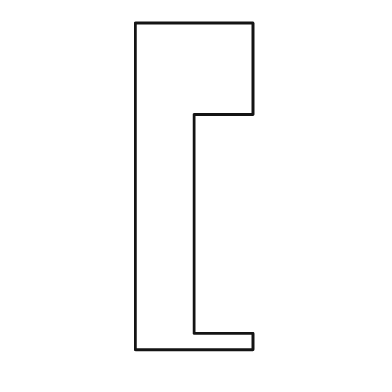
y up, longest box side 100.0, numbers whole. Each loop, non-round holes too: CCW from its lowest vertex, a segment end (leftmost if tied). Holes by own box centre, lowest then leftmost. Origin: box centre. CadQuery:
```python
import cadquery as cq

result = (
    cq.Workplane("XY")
    .moveTo(-18.0, -50.0)
    .lineTo(18.0, -50.0)
    .lineTo(18.0, -45.0)
    .lineTo(0.0, -45.0)
    .lineTo(0.0, 22.0)
    .lineTo(18.0, 22.0)
    .lineTo(18.0, 50.0)
    .lineTo(-18.0, 50.0)
    .close()
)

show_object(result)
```